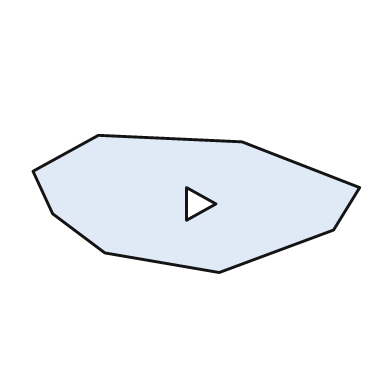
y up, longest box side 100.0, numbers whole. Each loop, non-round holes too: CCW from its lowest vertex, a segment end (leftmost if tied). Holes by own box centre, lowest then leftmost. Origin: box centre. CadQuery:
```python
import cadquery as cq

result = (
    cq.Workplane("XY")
    .moveTo(7.0, -21.0)
    .lineTo(42.0, -8.0)
    .lineTo(50.0, 5.0)
    .lineTo(14.0, 19.0)
    .lineTo(-30.0, 21.0)
    .lineTo(-50.0, 10.0)
    .lineTo(-44.0, -3.0)
    .lineTo(-28.0, -15.0)
    .close()
    .moveTo(-3.0, -5.0)
    .lineTo(6.0, 0.0)
    .lineTo(-3.0, 5.0)
    .close()
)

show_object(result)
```